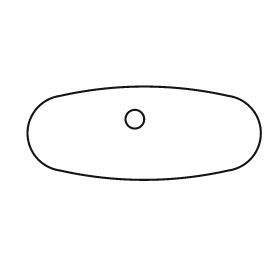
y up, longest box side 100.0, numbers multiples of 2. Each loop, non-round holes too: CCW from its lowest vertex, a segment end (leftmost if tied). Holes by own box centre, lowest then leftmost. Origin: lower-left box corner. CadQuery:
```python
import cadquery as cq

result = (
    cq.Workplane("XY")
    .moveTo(14.0, 4.0)
    .threePointArc((50.0, 0.0), (86.0, 4.0))
    .threePointArc((100.0, 20.0), (86.0, 36.0))
    .threePointArc((50.0, 40.0), (14.0, 36.0))
    .threePointArc((0.0, 20.0), (14.0, 4.0))
    .close()
    .moveTo(46.0, 26.0)
    .circle(4.0)
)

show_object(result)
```